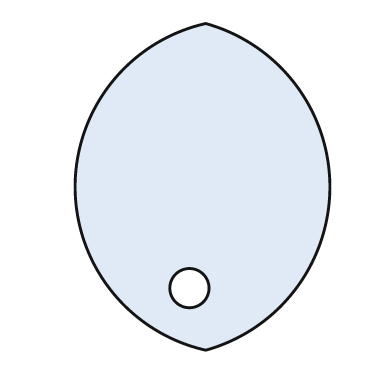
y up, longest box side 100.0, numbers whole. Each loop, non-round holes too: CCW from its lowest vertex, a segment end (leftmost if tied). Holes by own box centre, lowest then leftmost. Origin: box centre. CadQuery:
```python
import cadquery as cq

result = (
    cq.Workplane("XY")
    .moveTo(1.0, -50.0)
    .threePointArc((39.0, 0.0), (1.0, 50.0))
    .threePointArc((-39.0, 0.0), (1.0, -50.0))
    .close()
    .moveTo(-4.0, -31.0)
    .circle(6.0)
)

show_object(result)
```